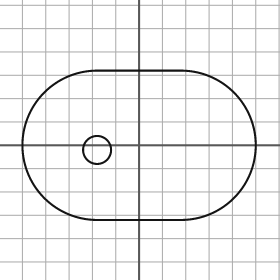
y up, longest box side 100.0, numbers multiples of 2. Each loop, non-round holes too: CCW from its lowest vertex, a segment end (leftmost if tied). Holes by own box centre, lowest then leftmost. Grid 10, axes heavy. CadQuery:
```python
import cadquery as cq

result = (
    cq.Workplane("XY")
    .moveTo(-18.0, -32.0)
    .lineTo(18.0, -32.0)
    .threePointArc((50.0, 0.0), (18.0, 32.0))
    .lineTo(-18.0, 32.0)
    .threePointArc((-50.0, 0.0), (-18.0, -32.0))
    .close()
    .moveTo(-18.0, -2.0)
    .circle(6.0)
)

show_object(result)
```